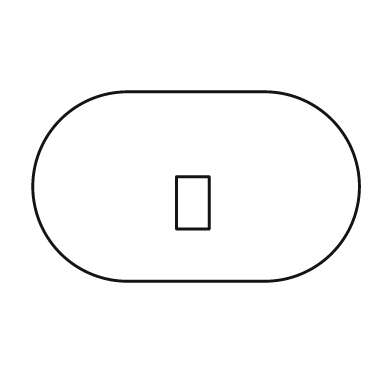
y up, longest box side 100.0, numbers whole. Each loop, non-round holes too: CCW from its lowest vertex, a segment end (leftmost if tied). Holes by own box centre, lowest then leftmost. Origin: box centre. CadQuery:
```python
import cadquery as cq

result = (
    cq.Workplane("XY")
    .moveTo(-21.0, -29.0)
    .lineTo(21.0, -29.0)
    .threePointArc((50.0, 0.0), (21.0, 29.0))
    .lineTo(-21.0, 29.0)
    .threePointArc((-50.0, 0.0), (-21.0, -29.0))
    .close()
    .moveTo(-6.0, -13.0)
    .lineTo(4.0, -13.0)
    .lineTo(4.0, 3.0)
    .lineTo(-6.0, 3.0)
    .close()
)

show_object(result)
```